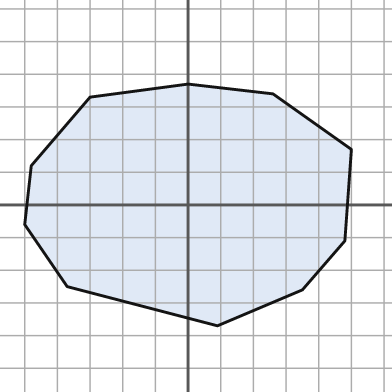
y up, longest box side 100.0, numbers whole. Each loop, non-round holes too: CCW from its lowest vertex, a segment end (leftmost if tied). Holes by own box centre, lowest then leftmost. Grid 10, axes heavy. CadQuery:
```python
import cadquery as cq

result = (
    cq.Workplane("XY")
    .moveTo(9.0, -37.0)
    .lineTo(35.0, -26.0)
    .lineTo(48.0, -11.0)
    .lineTo(50.0, 17.0)
    .lineTo(26.0, 34.0)
    .lineTo(0.0, 37.0)
    .lineTo(-30.0, 33.0)
    .lineTo(-48.0, 12.0)
    .lineTo(-50.0, -6.0)
    .lineTo(-37.0, -25.0)
    .close()
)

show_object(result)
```